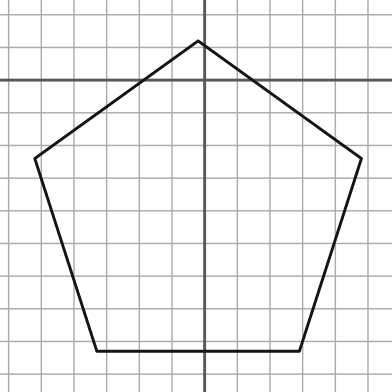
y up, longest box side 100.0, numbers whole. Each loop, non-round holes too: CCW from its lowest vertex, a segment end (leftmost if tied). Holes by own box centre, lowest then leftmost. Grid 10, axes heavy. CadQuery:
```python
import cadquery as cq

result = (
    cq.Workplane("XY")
    .moveTo(-33.0, -83.0)
    .lineTo(29.0, -83.0)
    .lineTo(48.0, -24.0)
    .lineTo(-2.0, 12.0)
    .lineTo(-52.0, -24.0)
    .close()
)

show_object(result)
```